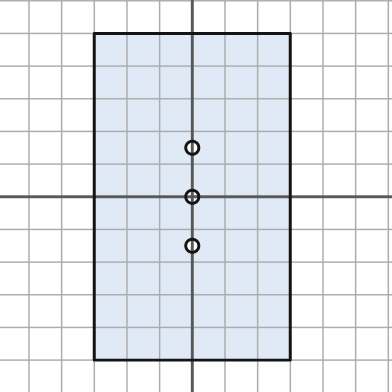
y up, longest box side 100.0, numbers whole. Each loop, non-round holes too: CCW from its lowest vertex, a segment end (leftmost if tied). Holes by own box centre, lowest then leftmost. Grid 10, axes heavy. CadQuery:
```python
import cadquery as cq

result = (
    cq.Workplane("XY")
    .moveTo(-30.0, -50.0)
    .lineTo(30.0, -50.0)
    .lineTo(30.0, 50.0)
    .lineTo(-30.0, 50.0)
    .close()
    .moveTo(0.0, -15.0)
    .circle(2.0)
    .moveTo(0.0, 0.0)
    .circle(2.0)
    .moveTo(0.0, 15.0)
    .circle(2.0)
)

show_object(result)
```